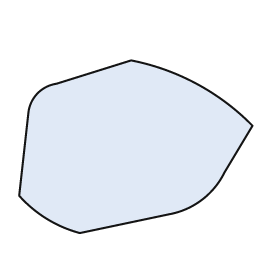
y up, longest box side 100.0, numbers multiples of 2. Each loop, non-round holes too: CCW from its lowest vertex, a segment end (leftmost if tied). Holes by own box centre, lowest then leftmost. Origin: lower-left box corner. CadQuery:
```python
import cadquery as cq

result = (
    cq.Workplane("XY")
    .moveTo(26.0, 0.0)
    .lineTo(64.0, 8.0)
    .threePointArc((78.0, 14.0), (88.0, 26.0))
    .lineTo(100.0, 46.0)
    .threePointArc((76.0, 64.0), (48.0, 74.0))
    .lineTo(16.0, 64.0)
    .threePointArc((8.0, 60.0), (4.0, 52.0))
    .lineTo(0.0, 16.0)
    .threePointArc((12.0, 6.0), (26.0, 0.0))
    .close()
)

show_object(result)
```